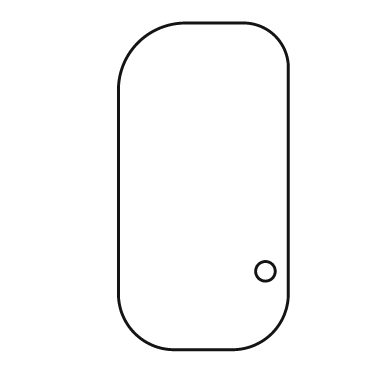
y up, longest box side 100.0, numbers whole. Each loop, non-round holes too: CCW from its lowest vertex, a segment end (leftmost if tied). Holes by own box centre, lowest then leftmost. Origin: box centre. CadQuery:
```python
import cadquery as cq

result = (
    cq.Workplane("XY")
    .moveTo(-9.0, -50.0)
    .lineTo(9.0, -50.0)
    .threePointArc((21.0, -45.0), (26.0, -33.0))
    .lineTo(26.0, 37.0)
    .threePointArc((22.0, 46.0), (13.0, 50.0))
    .lineTo(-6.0, 50.0)
    .threePointArc((-20.0, 44.0), (-26.0, 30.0))
    .lineTo(-26.0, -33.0)
    .threePointArc((-21.0, -45.0), (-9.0, -50.0))
    .close()
    .moveTo(19.0, -26.0)
    .circle(3.0)
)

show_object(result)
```